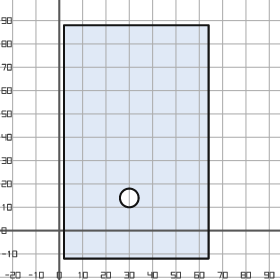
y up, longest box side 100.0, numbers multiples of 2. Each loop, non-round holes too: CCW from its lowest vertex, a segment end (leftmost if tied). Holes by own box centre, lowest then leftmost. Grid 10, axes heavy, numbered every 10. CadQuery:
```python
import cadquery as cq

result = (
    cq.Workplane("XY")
    .moveTo(2.0, -12.0)
    .lineTo(64.0, -12.0)
    .lineTo(64.0, 88.0)
    .lineTo(2.0, 88.0)
    .close()
    .moveTo(30.0, 14.0)
    .circle(4.0)
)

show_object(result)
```